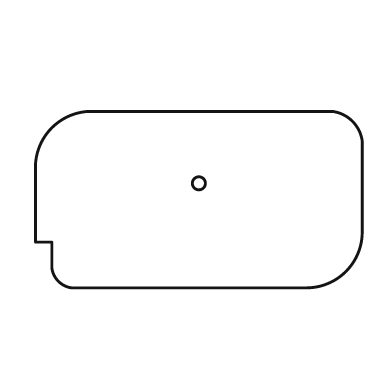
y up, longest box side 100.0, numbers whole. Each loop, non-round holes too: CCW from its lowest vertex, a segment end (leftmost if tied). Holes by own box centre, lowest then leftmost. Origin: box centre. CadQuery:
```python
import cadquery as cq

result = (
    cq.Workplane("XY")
    .moveTo(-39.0, -27.0)
    .lineTo(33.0, -27.0)
    .threePointArc((45.0, -22.0), (50.0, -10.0))
    .lineTo(50.0, 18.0)
    .threePointArc((47.0, 24.0), (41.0, 27.0))
    .lineTo(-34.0, 27.0)
    .threePointArc((-45.0, 22.0), (-50.0, 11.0))
    .lineTo(-50.0, -13.0)
    .lineTo(-45.0, -13.0)
    .lineTo(-45.0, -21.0)
    .threePointArc((-43.0, -25.0), (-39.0, -27.0))
    .close()
    .moveTo(0.0, 5.0)
    .circle(2.0)
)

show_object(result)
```